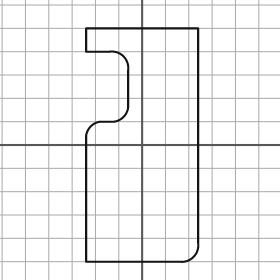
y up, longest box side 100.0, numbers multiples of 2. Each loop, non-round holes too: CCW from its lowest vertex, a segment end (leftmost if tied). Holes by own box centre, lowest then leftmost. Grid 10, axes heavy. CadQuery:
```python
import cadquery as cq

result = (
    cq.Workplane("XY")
    .moveTo(-24.0, -50.0)
    .lineTo(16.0, -50.0)
    .threePointArc((22.0, -48.0), (24.0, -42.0))
    .lineTo(24.0, 50.0)
    .lineTo(-24.0, 50.0)
    .lineTo(-24.0, 40.0)
    .lineTo(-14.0, 40.0)
    .threePointArc((-8.0, 38.0), (-6.0, 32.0))
    .lineTo(-6.0, 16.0)
    .threePointArc((-8.0, 12.0), (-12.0, 10.0))
    .lineTo(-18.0, 10.0)
    .threePointArc((-22.0, 8.0), (-24.0, 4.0))
    .close()
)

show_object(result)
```